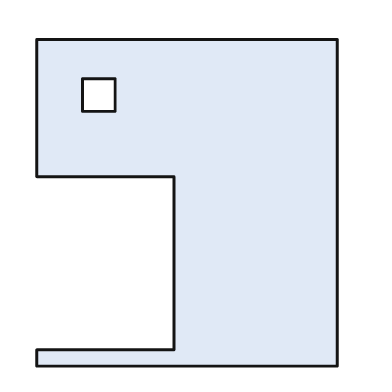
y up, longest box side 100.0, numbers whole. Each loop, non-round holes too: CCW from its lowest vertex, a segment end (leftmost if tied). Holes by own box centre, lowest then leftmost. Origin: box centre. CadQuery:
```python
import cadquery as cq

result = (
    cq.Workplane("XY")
    .moveTo(-46.0, -50.0)
    .lineTo(46.0, -50.0)
    .lineTo(46.0, 50.0)
    .lineTo(-46.0, 50.0)
    .lineTo(-46.0, 8.0)
    .lineTo(-4.0, 8.0)
    .lineTo(-4.0, -45.0)
    .lineTo(-46.0, -45.0)
    .close()
    .moveTo(-32.0, 28.0)
    .lineTo(-22.0, 28.0)
    .lineTo(-22.0, 38.0)
    .lineTo(-32.0, 38.0)
    .close()
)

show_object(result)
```